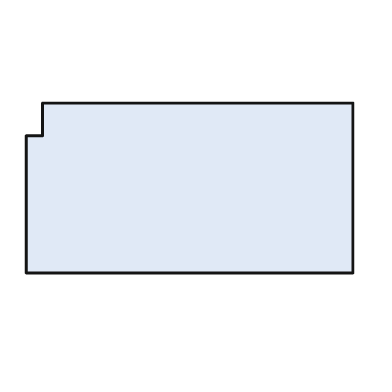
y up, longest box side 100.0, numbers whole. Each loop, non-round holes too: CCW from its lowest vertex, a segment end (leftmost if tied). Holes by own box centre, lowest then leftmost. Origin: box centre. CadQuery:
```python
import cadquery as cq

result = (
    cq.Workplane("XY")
    .moveTo(-50.0, -26.0)
    .lineTo(50.0, -26.0)
    .lineTo(50.0, 26.0)
    .lineTo(-45.0, 26.0)
    .lineTo(-45.0, 16.0)
    .lineTo(-50.0, 16.0)
    .close()
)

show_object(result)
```